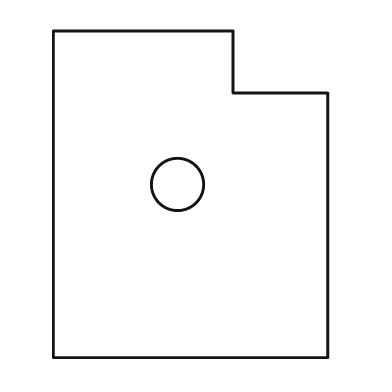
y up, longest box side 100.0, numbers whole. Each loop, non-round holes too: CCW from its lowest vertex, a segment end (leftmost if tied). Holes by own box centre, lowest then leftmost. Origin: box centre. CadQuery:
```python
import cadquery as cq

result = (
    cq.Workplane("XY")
    .moveTo(-42.0, -50.0)
    .lineTo(42.0, -50.0)
    .lineTo(42.0, 31.0)
    .lineTo(13.0, 31.0)
    .lineTo(13.0, 50.0)
    .lineTo(-42.0, 50.0)
    .close()
    .moveTo(-4.0, 3.0)
    .circle(8.0)
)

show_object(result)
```